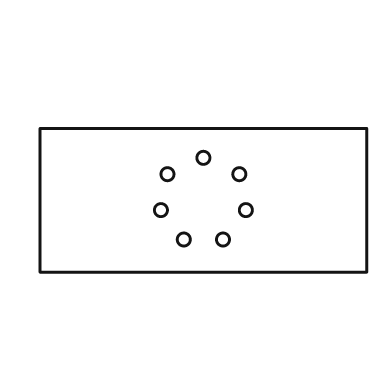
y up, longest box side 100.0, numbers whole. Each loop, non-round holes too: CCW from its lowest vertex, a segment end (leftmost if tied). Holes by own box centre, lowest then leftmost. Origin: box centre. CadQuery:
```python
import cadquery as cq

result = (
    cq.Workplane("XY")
    .moveTo(-50.0, -22.0)
    .lineTo(50.0, -22.0)
    .lineTo(50.0, 22.0)
    .lineTo(-50.0, 22.0)
    .close()
    .moveTo(-6.0, -12.0)
    .circle(2.0)
    .moveTo(6.0, -12.0)
    .circle(2.0)
    .moveTo(-13.0, -3.0)
    .circle(2.0)
    .moveTo(13.0, -3.0)
    .circle(2.0)
    .moveTo(-11.0, 8.0)
    .circle(2.0)
    .moveTo(11.0, 8.0)
    .circle(2.0)
    .moveTo(0.0, 13.0)
    .circle(2.0)
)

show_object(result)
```